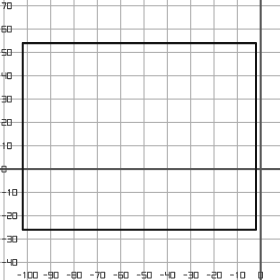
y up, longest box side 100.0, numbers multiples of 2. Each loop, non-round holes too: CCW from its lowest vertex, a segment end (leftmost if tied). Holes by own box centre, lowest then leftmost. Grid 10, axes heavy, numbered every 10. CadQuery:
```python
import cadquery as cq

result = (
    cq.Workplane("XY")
    .moveTo(-102.0, -26.0)
    .lineTo(-2.0, -26.0)
    .lineTo(-2.0, 54.0)
    .lineTo(-102.0, 54.0)
    .close()
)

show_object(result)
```